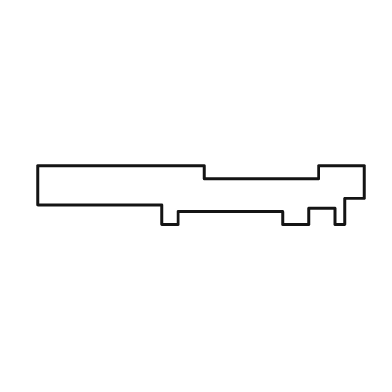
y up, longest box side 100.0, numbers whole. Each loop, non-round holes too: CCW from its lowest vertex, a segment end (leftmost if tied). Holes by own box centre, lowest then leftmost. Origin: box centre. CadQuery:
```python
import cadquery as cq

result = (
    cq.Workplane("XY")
    .moveTo(-12.0, -9.0)
    .lineTo(-7.0, -9.0)
    .lineTo(-7.0, -5.0)
    .lineTo(25.0, -5.0)
    .lineTo(25.0, -9.0)
    .lineTo(33.0, -9.0)
    .lineTo(33.0, -4.0)
    .lineTo(41.0, -4.0)
    .lineTo(41.0, -9.0)
    .lineTo(44.0, -9.0)
    .lineTo(44.0, -1.0)
    .lineTo(50.0, -1.0)
    .lineTo(50.0, 9.0)
    .lineTo(36.0, 9.0)
    .lineTo(36.0, 5.0)
    .lineTo(1.0, 5.0)
    .lineTo(1.0, 9.0)
    .lineTo(-50.0, 9.0)
    .lineTo(-50.0, -3.0)
    .lineTo(-12.0, -3.0)
    .close()
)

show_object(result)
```